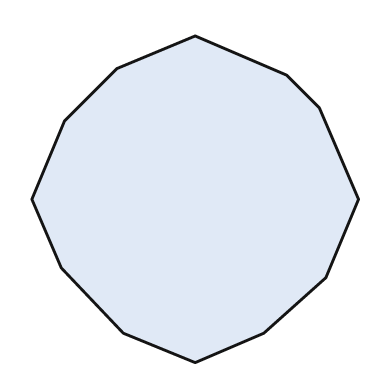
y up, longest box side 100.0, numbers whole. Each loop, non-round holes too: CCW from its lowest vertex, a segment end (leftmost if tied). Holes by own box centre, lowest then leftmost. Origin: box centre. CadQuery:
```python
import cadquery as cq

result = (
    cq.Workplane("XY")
    .moveTo(0.0, -50.0)
    .lineTo(21.0, -41.0)
    .lineTo(40.0, -24.0)
    .lineTo(50.0, 0.0)
    .lineTo(38.0, 28.0)
    .lineTo(28.0, 38.0)
    .lineTo(0.0, 50.0)
    .lineTo(-24.0, 40.0)
    .lineTo(-40.0, 24.0)
    .lineTo(-50.0, 0.0)
    .lineTo(-41.0, -21.0)
    .lineTo(-22.0, -41.0)
    .close()
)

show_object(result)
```